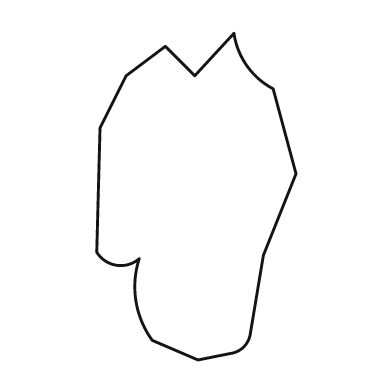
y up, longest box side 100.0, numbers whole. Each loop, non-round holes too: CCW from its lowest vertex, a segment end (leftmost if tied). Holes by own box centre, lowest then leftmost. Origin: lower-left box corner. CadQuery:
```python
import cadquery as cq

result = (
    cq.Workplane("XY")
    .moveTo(31.0, 0.0)
    .lineTo(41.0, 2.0)
    .threePointArc((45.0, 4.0), (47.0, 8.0))
    .lineTo(51.0, 32.0)
    .lineTo(61.0, 57.0)
    .lineTo(54.0, 83.0)
    .threePointArc((46.0, 90.0), (42.0, 100.0))
    .lineTo(30.0, 87.0)
    .lineTo(21.0, 96.0)
    .lineTo(9.0, 87.0)
    .lineTo(1.0, 71.0)
    .lineTo(0.0, 33.0)
    .threePointArc((6.0, 29.0), (13.0, 31.0))
    .threePointArc((12.0, 18.0), (17.0, 6.0))
    .close()
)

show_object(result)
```